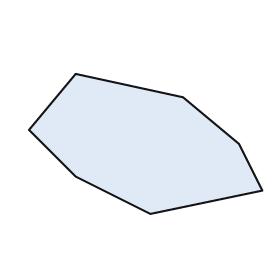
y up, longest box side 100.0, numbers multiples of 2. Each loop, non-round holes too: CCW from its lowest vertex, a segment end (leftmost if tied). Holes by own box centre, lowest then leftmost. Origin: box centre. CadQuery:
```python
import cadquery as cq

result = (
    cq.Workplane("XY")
    .moveTo(2.0, -30.0)
    .lineTo(50.0, -20.0)
    .lineTo(40.0, 0.0)
    .lineTo(16.0, 20.0)
    .lineTo(-30.0, 30.0)
    .lineTo(-50.0, 6.0)
    .lineTo(-30.0, -14.0)
    .close()
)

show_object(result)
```